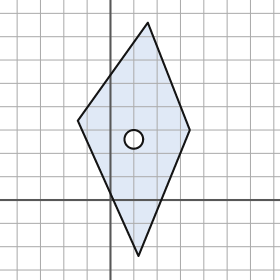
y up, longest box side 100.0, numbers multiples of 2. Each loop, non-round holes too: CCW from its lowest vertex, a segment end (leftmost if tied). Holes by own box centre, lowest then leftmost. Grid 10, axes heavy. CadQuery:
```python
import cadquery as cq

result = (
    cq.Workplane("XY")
    .moveTo(12.0, -24.0)
    .lineTo(34.0, 30.0)
    .lineTo(16.0, 76.0)
    .lineTo(-14.0, 34.0)
    .close()
    .moveTo(10.0, 26.0)
    .circle(4.0)
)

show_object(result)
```